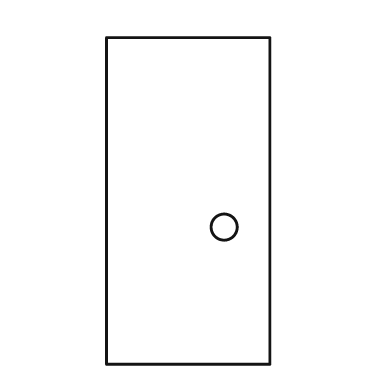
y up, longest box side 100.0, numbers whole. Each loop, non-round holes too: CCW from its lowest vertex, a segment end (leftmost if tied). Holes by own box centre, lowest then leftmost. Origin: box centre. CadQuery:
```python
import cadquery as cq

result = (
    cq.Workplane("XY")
    .moveTo(-25.0, -50.0)
    .lineTo(25.0, -50.0)
    .lineTo(25.0, 50.0)
    .lineTo(-25.0, 50.0)
    .close()
    .moveTo(11.0, -8.0)
    .circle(4.0)
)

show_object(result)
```